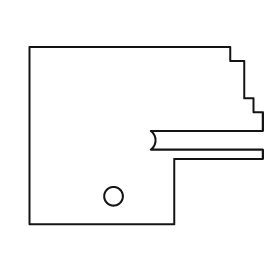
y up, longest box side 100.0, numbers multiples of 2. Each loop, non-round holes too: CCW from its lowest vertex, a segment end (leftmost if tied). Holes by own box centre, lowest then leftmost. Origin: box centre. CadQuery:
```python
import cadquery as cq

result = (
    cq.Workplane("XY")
    .moveTo(-50.0, -38.0)
    .lineTo(12.0, -38.0)
    .lineTo(12.0, -10.0)
    .lineTo(50.0, -10.0)
    .lineTo(50.0, -6.0)
    .lineTo(2.0, -6.0)
    .threePointArc((4.0, -2.0), (2.0, 2.0))
    .lineTo(50.0, 2.0)
    .lineTo(50.0, 10.0)
    .lineTo(46.0, 10.0)
    .lineTo(46.0, 16.0)
    .lineTo(42.0, 16.0)
    .lineTo(42.0, 32.0)
    .lineTo(36.0, 32.0)
    .lineTo(36.0, 38.0)
    .lineTo(-50.0, 38.0)
    .close()
    .moveTo(-14.0, -26.0)
    .circle(4.0)
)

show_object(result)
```